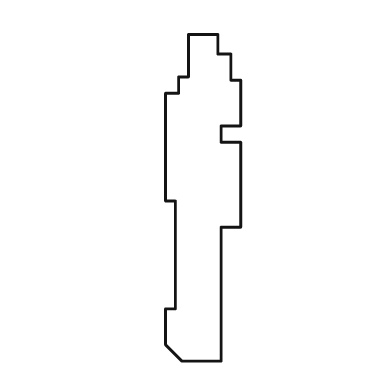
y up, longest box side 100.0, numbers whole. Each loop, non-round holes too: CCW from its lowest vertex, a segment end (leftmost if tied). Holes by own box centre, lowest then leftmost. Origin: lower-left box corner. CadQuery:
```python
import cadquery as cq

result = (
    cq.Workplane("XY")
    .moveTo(5.0, 0.0)
    .lineTo(17.0, 0.0)
    .lineTo(17.0, 41.0)
    .lineTo(23.0, 41.0)
    .lineTo(23.0, 67.0)
    .lineTo(17.0, 67.0)
    .lineTo(17.0, 72.0)
    .lineTo(23.0, 72.0)
    .lineTo(23.0, 86.0)
    .lineTo(20.0, 86.0)
    .lineTo(20.0, 94.0)
    .lineTo(16.0, 94.0)
    .lineTo(16.0, 100.0)
    .lineTo(7.0, 100.0)
    .lineTo(7.0, 87.0)
    .lineTo(4.0, 87.0)
    .lineTo(4.0, 82.0)
    .lineTo(0.0, 82.0)
    .lineTo(0.0, 49.0)
    .lineTo(3.0, 49.0)
    .lineTo(3.0, 16.0)
    .lineTo(0.0, 16.0)
    .lineTo(0.0, 5.0)
    .close()
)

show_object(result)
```